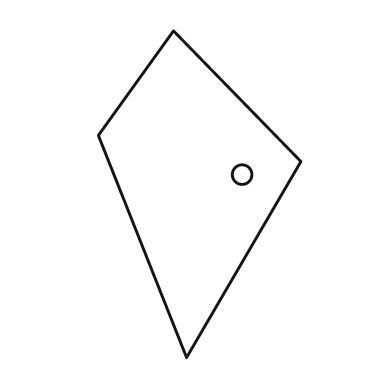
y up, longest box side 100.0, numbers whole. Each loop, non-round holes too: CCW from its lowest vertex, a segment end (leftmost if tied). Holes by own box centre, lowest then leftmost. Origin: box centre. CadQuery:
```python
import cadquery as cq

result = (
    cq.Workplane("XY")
    .moveTo(-4.0, -50.0)
    .lineTo(31.0, 10.0)
    .lineTo(-8.0, 50.0)
    .lineTo(-31.0, 18.0)
    .close()
    .moveTo(13.0, 6.0)
    .circle(3.0)
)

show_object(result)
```